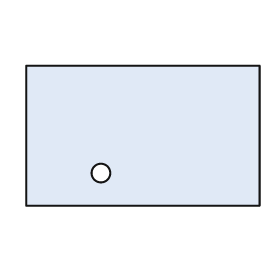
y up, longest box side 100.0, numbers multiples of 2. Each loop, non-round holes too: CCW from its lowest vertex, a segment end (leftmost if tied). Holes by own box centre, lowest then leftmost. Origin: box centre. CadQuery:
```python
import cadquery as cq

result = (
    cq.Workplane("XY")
    .moveTo(-50.0, -30.0)
    .lineTo(50.0, -30.0)
    .lineTo(50.0, 30.0)
    .lineTo(-50.0, 30.0)
    .close()
    .moveTo(-18.0, -16.0)
    .circle(4.0)
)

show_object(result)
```